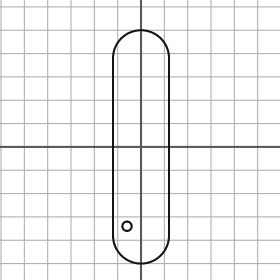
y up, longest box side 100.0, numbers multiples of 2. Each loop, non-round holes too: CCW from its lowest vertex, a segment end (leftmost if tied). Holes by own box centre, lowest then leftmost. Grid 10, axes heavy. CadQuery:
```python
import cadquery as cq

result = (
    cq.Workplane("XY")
    .moveTo(-12.0, -38.0)
    .threePointArc((0.0, -50.0), (12.0, -38.0))
    .lineTo(12.0, 38.0)
    .threePointArc((0.0, 50.0), (-12.0, 38.0))
    .close()
    .moveTo(-6.0, -34.0)
    .circle(2.0)
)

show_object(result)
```